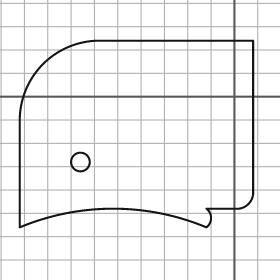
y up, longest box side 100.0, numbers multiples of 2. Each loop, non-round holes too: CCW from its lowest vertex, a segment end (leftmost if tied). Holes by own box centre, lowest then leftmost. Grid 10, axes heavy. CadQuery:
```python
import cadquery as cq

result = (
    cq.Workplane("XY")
    .moveTo(-92.0, -56.0)
    .threePointArc((-52.0, -48.0), (-12.0, -56.0))
    .threePointArc((-10.0, -52.0), (-12.0, -48.0))
    .lineTo(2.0, -48.0)
    .threePointArc((6.0, -46.0), (8.0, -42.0))
    .lineTo(8.0, 24.0)
    .lineTo(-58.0, 24.0)
    .threePointArc((-82.0, 14.0), (-92.0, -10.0))
    .close()
    .moveTo(-66.0, -28.0)
    .circle(4.0)
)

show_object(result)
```